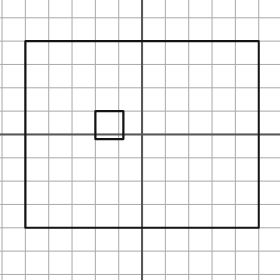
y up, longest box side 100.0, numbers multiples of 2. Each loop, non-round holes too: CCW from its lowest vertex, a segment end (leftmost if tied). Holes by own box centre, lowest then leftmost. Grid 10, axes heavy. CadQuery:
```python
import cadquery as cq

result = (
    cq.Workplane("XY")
    .moveTo(-50.0, -40.0)
    .lineTo(50.0, -40.0)
    .lineTo(50.0, 40.0)
    .lineTo(-50.0, 40.0)
    .close()
    .moveTo(-20.0, -2.0)
    .lineTo(-8.0, -2.0)
    .lineTo(-8.0, 10.0)
    .lineTo(-20.0, 10.0)
    .close()
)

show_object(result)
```